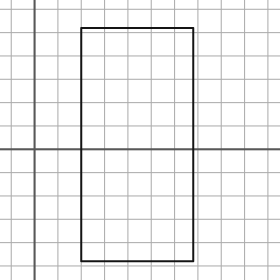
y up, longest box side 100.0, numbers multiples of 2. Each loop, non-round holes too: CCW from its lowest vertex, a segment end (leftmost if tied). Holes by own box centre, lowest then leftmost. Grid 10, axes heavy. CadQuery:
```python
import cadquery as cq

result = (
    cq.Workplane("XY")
    .moveTo(20.0, -48.0)
    .lineTo(68.0, -48.0)
    .lineTo(68.0, 52.0)
    .lineTo(20.0, 52.0)
    .close()
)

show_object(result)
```